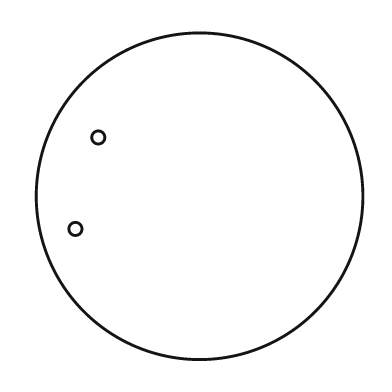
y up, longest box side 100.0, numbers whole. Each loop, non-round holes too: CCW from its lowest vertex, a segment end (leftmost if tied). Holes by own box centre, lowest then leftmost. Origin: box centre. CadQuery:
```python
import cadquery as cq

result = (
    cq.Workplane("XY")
    .moveTo(0.0, 0.0)
    .circle(50.0)
    .moveTo(-38.0, -10.0)
    .circle(2.0)
    .moveTo(-31.0, 18.0)
    .circle(2.0)
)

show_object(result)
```